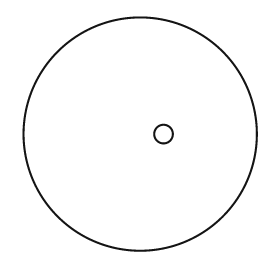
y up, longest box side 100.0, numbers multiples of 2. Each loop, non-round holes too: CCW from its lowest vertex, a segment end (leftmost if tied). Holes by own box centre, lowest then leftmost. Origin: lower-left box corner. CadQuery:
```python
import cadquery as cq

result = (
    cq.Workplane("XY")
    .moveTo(50.0, 50.0)
    .circle(50.0)
    .moveTo(60.0, 50.0)
    .circle(4.0)
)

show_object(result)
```